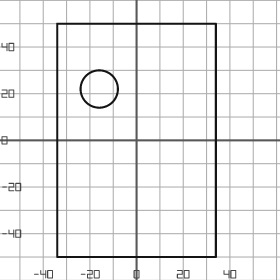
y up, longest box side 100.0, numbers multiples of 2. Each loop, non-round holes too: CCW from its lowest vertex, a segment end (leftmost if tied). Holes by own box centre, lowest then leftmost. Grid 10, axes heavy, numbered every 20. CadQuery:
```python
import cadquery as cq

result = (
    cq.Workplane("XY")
    .moveTo(-34.0, -50.0)
    .lineTo(34.0, -50.0)
    .lineTo(34.0, 50.0)
    .lineTo(-34.0, 50.0)
    .close()
    .moveTo(-16.0, 22.0)
    .circle(8.0)
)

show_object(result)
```